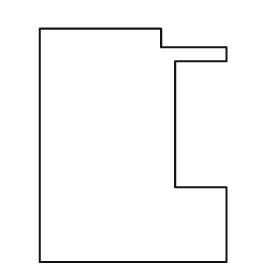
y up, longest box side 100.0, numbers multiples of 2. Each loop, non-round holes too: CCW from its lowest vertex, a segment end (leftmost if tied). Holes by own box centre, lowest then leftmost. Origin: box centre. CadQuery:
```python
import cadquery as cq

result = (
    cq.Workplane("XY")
    .moveTo(-40.0, -50.0)
    .lineTo(40.0, -50.0)
    .lineTo(40.0, -18.0)
    .lineTo(18.0, -18.0)
    .lineTo(18.0, 36.0)
    .lineTo(40.0, 36.0)
    .lineTo(40.0, 42.0)
    .lineTo(12.0, 42.0)
    .lineTo(12.0, 50.0)
    .lineTo(-40.0, 50.0)
    .close()
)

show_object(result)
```